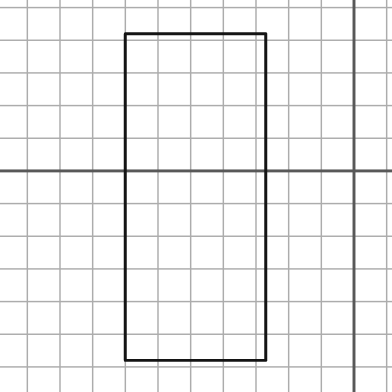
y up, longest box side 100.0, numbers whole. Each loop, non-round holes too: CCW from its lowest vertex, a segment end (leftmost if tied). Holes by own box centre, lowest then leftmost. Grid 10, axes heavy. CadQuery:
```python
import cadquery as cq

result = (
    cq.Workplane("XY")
    .moveTo(-70.0, -58.0)
    .lineTo(-27.0, -58.0)
    .lineTo(-27.0, 42.0)
    .lineTo(-70.0, 42.0)
    .close()
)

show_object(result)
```